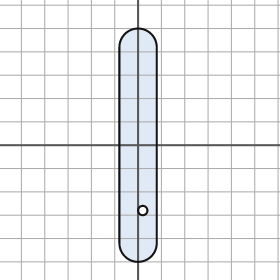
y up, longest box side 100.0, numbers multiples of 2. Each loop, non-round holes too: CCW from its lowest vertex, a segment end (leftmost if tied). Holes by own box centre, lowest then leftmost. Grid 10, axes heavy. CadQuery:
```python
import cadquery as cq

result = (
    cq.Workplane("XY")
    .moveTo(-8.0, -42.0)
    .threePointArc((0.0, -50.0), (8.0, -42.0))
    .lineTo(8.0, 42.0)
    .threePointArc((0.0, 50.0), (-8.0, 42.0))
    .close()
    .moveTo(2.0, -28.0)
    .circle(2.0)
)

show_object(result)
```